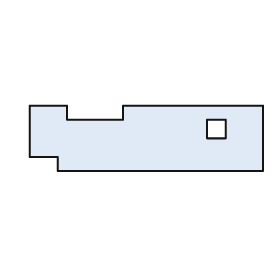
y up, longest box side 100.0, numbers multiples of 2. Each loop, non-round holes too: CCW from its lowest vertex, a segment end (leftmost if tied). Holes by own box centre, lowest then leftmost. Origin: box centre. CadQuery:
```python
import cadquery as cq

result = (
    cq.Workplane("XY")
    .moveTo(-38.0, -14.0)
    .lineTo(50.0, -14.0)
    .lineTo(50.0, 14.0)
    .lineTo(-10.0, 14.0)
    .lineTo(-10.0, 8.0)
    .lineTo(-34.0, 8.0)
    .lineTo(-34.0, 14.0)
    .lineTo(-50.0, 14.0)
    .lineTo(-50.0, -8.0)
    .lineTo(-38.0, -8.0)
    .close()
    .moveTo(26.0, 0.0)
    .lineTo(34.0, 0.0)
    .lineTo(34.0, 8.0)
    .lineTo(26.0, 8.0)
    .close()
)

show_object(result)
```